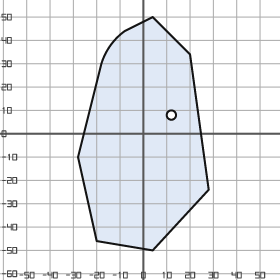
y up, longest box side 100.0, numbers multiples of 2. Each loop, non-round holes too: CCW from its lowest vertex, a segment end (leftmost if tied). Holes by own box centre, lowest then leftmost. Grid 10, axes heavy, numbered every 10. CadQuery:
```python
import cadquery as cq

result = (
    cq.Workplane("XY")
    .moveTo(4.0, -50.0)
    .lineTo(28.0, -24.0)
    .lineTo(20.0, 34.0)
    .lineTo(4.0, 50.0)
    .lineTo(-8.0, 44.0)
    .threePointArc((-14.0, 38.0), (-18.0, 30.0))
    .lineTo(-28.0, -10.0)
    .lineTo(-20.0, -46.0)
    .close()
    .moveTo(12.0, 8.0)
    .circle(2.0)
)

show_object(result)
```